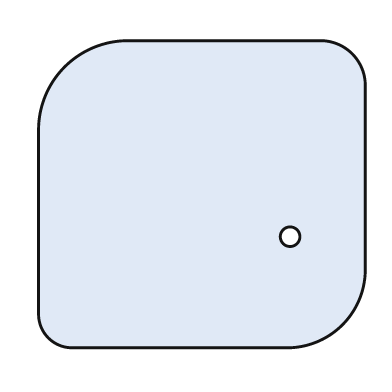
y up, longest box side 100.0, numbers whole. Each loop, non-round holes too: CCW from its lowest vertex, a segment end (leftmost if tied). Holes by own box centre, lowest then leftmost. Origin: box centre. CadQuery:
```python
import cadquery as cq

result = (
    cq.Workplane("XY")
    .moveTo(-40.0, -47.0)
    .lineTo(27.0, -47.0)
    .threePointArc((43.0, -40.0), (50.0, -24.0))
    .lineTo(50.0, 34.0)
    .threePointArc((46.0, 43.0), (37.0, 47.0))
    .lineTo(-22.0, 47.0)
    .threePointArc((-42.0, 39.0), (-50.0, 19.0))
    .lineTo(-50.0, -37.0)
    .threePointArc((-47.0, -44.0), (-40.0, -47.0))
    .close()
    .moveTo(27.0, -13.0)
    .circle(3.0)
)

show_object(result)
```